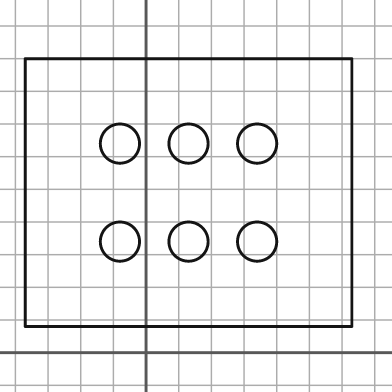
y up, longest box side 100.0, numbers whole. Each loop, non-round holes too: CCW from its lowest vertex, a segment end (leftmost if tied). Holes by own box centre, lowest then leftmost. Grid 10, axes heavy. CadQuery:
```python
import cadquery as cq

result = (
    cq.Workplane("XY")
    .moveTo(-37.0, 8.0)
    .lineTo(63.0, 8.0)
    .lineTo(63.0, 90.0)
    .lineTo(-37.0, 90.0)
    .close()
    .moveTo(-8.0, 34.0)
    .circle(6.0)
    .moveTo(13.0, 34.0)
    .circle(6.0)
    .moveTo(34.0, 34.0)
    .circle(6.0)
    .moveTo(-8.0, 64.0)
    .circle(6.0)
    .moveTo(13.0, 64.0)
    .circle(6.0)
    .moveTo(34.0, 64.0)
    .circle(6.0)
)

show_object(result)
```